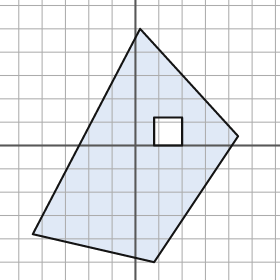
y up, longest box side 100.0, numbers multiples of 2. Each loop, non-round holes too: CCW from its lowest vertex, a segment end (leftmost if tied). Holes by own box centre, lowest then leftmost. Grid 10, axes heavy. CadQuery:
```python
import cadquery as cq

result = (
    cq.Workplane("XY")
    .moveTo(8.0, -50.0)
    .lineTo(44.0, 4.0)
    .lineTo(2.0, 50.0)
    .lineTo(-44.0, -38.0)
    .close()
    .moveTo(8.0, 0.0)
    .lineTo(20.0, 0.0)
    .lineTo(20.0, 12.0)
    .lineTo(8.0, 12.0)
    .close()
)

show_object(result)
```